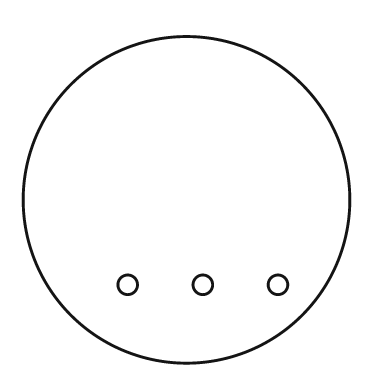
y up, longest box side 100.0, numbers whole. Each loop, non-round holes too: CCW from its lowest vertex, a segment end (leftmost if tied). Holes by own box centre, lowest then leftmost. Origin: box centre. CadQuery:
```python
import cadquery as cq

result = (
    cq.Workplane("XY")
    .moveTo(0.0, 0.0)
    .circle(50.0)
    .moveTo(-18.0, -26.0)
    .circle(3.0)
    .moveTo(5.0, -26.0)
    .circle(3.0)
    .moveTo(28.0, -26.0)
    .circle(3.0)
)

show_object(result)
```